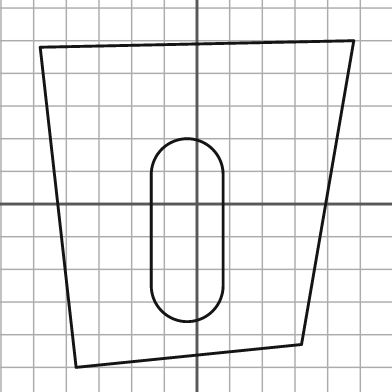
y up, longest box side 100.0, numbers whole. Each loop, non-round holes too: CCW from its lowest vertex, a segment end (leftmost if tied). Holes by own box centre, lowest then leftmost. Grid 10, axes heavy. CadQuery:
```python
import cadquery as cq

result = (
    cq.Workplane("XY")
    .moveTo(-37.0, -50.0)
    .lineTo(32.0, -43.0)
    .lineTo(48.0, 50.0)
    .lineTo(-48.0, 48.0)
    .close()
    .moveTo(-14.0, -25.0)
    .threePointArc((-3.0, -36.0), (8.0, -25.0))
    .lineTo(8.0, 9.0)
    .threePointArc((-3.0, 20.0), (-14.0, 9.0))
    .close()
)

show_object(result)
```